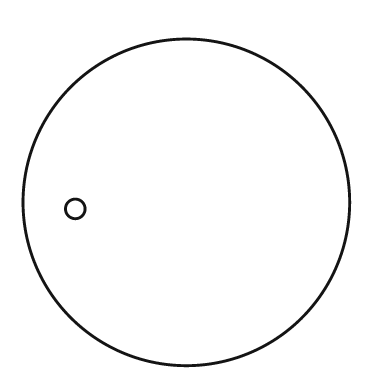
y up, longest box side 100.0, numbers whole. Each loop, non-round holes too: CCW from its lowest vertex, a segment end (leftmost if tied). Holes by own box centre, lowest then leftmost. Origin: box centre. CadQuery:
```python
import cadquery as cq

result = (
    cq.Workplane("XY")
    .moveTo(0.0, 0.0)
    .circle(50.0)
    .moveTo(-34.0, -2.0)
    .circle(3.0)
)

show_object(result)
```